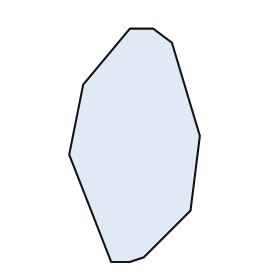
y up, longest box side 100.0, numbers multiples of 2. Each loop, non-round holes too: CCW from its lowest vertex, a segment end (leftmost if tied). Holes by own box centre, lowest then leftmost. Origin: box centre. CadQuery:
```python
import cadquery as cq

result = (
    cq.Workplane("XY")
    .moveTo(-10.0, -50.0)
    .lineTo(-2.0, -50.0)
    .lineTo(4.0, -48.0)
    .lineTo(24.0, -28.0)
    .lineTo(28.0, 4.0)
    .lineTo(16.0, 44.0)
    .lineTo(8.0, 50.0)
    .lineTo(-2.0, 50.0)
    .lineTo(-22.0, 26.0)
    .lineTo(-28.0, -4.0)
    .close()
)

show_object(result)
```